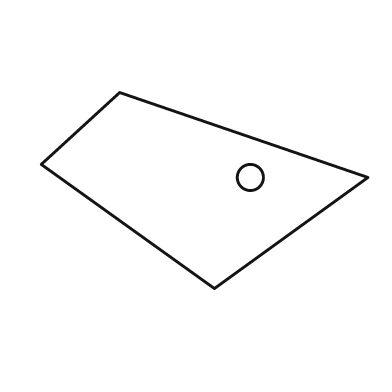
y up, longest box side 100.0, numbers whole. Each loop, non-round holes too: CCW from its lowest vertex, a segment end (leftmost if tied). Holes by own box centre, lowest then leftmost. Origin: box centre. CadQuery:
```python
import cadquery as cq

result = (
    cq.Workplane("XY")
    .moveTo(3.0, -30.0)
    .lineTo(50.0, 4.0)
    .lineTo(-26.0, 30.0)
    .lineTo(-50.0, 8.0)
    .close()
    .moveTo(14.0, 4.0)
    .circle(4.0)
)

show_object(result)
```